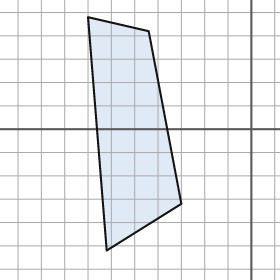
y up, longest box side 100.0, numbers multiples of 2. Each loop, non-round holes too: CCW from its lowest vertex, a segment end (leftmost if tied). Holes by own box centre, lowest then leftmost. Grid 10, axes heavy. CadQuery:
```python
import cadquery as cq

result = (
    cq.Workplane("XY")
    .moveTo(-62.0, -52.0)
    .lineTo(-30.0, -32.0)
    .lineTo(-44.0, 42.0)
    .lineTo(-70.0, 48.0)
    .close()
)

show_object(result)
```